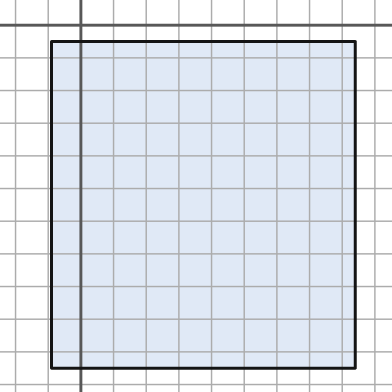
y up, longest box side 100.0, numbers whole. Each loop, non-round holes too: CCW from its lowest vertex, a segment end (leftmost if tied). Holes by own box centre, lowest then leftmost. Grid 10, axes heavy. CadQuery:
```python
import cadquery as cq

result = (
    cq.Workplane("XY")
    .moveTo(-9.0, -105.0)
    .lineTo(84.0, -105.0)
    .lineTo(84.0, -5.0)
    .lineTo(-9.0, -5.0)
    .close()
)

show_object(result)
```